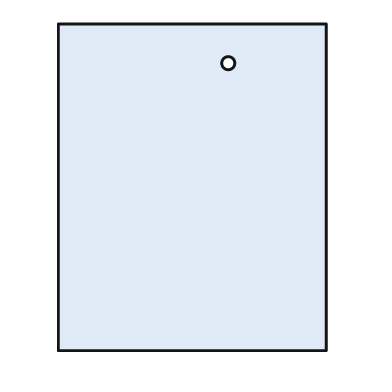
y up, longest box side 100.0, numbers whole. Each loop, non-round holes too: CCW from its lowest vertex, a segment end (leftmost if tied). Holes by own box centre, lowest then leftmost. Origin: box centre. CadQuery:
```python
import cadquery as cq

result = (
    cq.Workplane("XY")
    .moveTo(-41.0, -50.0)
    .lineTo(41.0, -50.0)
    .lineTo(41.0, 50.0)
    .lineTo(-41.0, 50.0)
    .close()
    .moveTo(11.0, 38.0)
    .circle(2.0)
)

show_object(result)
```